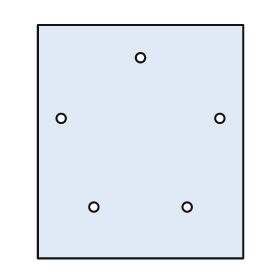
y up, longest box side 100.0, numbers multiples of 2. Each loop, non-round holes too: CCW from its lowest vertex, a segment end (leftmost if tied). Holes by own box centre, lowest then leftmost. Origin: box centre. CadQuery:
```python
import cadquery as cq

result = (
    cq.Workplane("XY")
    .moveTo(-44.0, -50.0)
    .lineTo(44.0, -50.0)
    .lineTo(44.0, 50.0)
    .lineTo(-44.0, 50.0)
    .close()
    .moveTo(-20.0, -28.0)
    .circle(2.0)
    .moveTo(20.0, -28.0)
    .circle(2.0)
    .moveTo(-34.0, 10.0)
    .circle(2.0)
    .moveTo(34.0, 10.0)
    .circle(2.0)
    .moveTo(0.0, 36.0)
    .circle(2.0)
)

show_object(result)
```